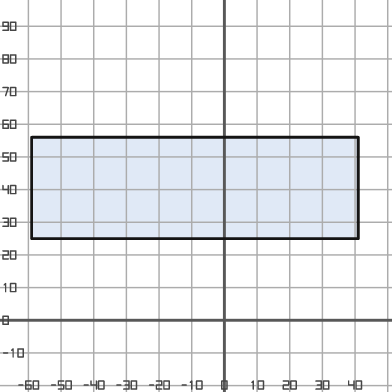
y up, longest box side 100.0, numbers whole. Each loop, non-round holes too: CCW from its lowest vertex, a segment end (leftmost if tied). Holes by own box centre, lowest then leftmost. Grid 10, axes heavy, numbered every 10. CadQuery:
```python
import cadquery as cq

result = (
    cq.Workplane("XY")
    .moveTo(-59.0, 25.0)
    .lineTo(41.0, 25.0)
    .lineTo(41.0, 56.0)
    .lineTo(-59.0, 56.0)
    .close()
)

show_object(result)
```